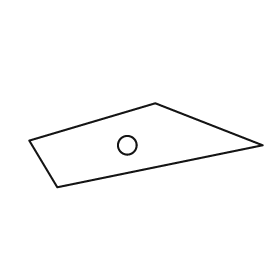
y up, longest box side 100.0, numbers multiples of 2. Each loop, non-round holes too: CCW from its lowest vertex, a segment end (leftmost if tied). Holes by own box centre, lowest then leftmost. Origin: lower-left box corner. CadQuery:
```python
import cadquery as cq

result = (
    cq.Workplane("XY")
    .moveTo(12.0, 0.0)
    .lineTo(100.0, 18.0)
    .lineTo(54.0, 36.0)
    .lineTo(0.0, 20.0)
    .close()
    .moveTo(42.0, 18.0)
    .circle(4.0)
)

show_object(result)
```